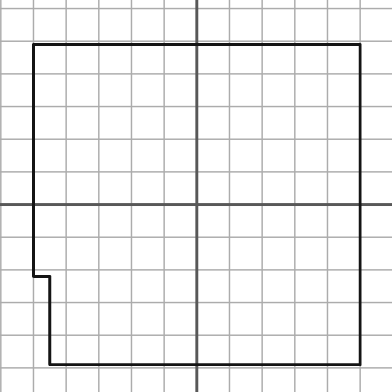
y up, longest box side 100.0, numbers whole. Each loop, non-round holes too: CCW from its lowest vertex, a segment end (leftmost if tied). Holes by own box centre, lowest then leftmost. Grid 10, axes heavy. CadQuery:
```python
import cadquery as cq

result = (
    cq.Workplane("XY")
    .moveTo(-45.0, -49.0)
    .lineTo(50.0, -49.0)
    .lineTo(50.0, 49.0)
    .lineTo(-50.0, 49.0)
    .lineTo(-50.0, -22.0)
    .lineTo(-45.0, -22.0)
    .close()
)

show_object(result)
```